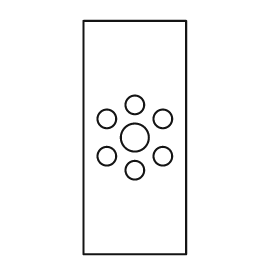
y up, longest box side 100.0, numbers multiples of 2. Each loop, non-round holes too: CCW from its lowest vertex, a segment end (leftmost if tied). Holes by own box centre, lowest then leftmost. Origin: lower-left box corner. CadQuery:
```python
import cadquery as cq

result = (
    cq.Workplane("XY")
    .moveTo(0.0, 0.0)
    .lineTo(44.0, 0.0)
    .lineTo(44.0, 100.0)
    .lineTo(0.0, 100.0)
    .close()
    .moveTo(22.0, 36.0)
    .circle(4.0)
    .moveTo(10.0, 42.0)
    .circle(4.0)
    .moveTo(34.0, 42.0)
    .circle(4.0)
    .moveTo(22.0, 50.0)
    .circle(6.0)
    .moveTo(10.0, 58.0)
    .circle(4.0)
    .moveTo(34.0, 58.0)
    .circle(4.0)
    .moveTo(22.0, 64.0)
    .circle(4.0)
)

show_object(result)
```